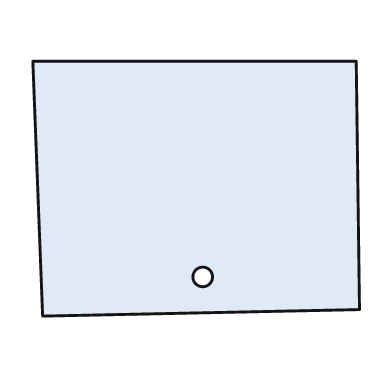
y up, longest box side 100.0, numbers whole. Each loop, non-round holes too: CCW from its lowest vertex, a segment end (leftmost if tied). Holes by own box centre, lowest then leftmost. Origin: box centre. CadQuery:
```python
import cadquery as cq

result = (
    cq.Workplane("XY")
    .moveTo(-47.0, -39.0)
    .lineTo(50.0, -37.0)
    .lineTo(49.0, 39.0)
    .lineTo(-50.0, 39.0)
    .close()
    .moveTo(2.0, -27.0)
    .circle(3.0)
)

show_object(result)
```